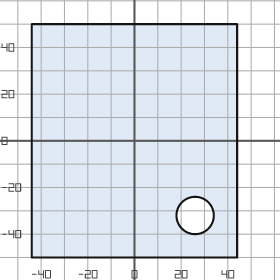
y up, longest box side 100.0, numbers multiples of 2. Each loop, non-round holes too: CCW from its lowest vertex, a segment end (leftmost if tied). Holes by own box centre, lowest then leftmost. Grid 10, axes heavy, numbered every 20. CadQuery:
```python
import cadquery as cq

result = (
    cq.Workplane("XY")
    .moveTo(-44.0, -50.0)
    .lineTo(44.0, -50.0)
    .lineTo(44.0, 50.0)
    .lineTo(-44.0, 50.0)
    .close()
    .moveTo(26.0, -32.0)
    .circle(8.0)
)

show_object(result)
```